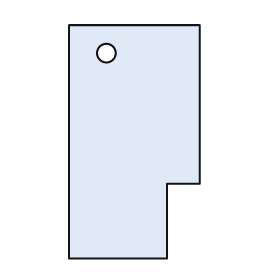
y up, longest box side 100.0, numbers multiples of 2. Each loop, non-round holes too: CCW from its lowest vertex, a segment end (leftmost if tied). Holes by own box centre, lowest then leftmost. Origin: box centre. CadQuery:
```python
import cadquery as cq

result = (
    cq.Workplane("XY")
    .moveTo(-28.0, -50.0)
    .lineTo(14.0, -50.0)
    .lineTo(14.0, -18.0)
    .lineTo(28.0, -18.0)
    .lineTo(28.0, 50.0)
    .lineTo(-28.0, 50.0)
    .close()
    .moveTo(-12.0, 38.0)
    .circle(4.0)
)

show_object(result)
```